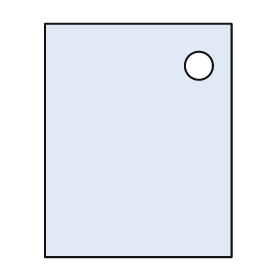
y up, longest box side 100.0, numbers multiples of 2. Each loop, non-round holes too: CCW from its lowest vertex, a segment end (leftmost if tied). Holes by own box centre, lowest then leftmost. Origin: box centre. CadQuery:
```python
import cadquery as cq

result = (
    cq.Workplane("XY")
    .moveTo(-40.0, -50.0)
    .lineTo(40.0, -50.0)
    .lineTo(40.0, 50.0)
    .lineTo(-40.0, 50.0)
    .close()
    .moveTo(26.0, 32.0)
    .circle(6.0)
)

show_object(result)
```